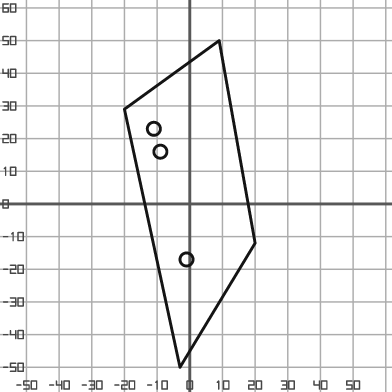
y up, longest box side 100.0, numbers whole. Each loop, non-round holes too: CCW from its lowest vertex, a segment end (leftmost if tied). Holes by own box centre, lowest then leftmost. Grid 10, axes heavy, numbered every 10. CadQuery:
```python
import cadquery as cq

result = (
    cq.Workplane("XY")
    .moveTo(-3.0, -50.0)
    .lineTo(20.0, -12.0)
    .lineTo(9.0, 50.0)
    .lineTo(-20.0, 29.0)
    .close()
    .moveTo(-1.0, -17.0)
    .circle(2.0)
    .moveTo(-9.0, 16.0)
    .circle(2.0)
    .moveTo(-11.0, 23.0)
    .circle(2.0)
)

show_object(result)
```